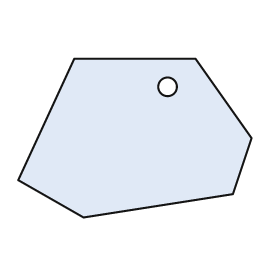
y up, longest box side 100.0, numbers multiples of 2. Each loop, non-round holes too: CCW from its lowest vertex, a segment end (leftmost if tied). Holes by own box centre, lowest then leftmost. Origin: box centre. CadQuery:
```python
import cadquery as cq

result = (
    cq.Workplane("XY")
    .moveTo(-22.0, -34.0)
    .lineTo(42.0, -24.0)
    .lineTo(50.0, 0.0)
    .lineTo(26.0, 34.0)
    .lineTo(-26.0, 34.0)
    .lineTo(-50.0, -18.0)
    .close()
    .moveTo(14.0, 22.0)
    .circle(4.0)
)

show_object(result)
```